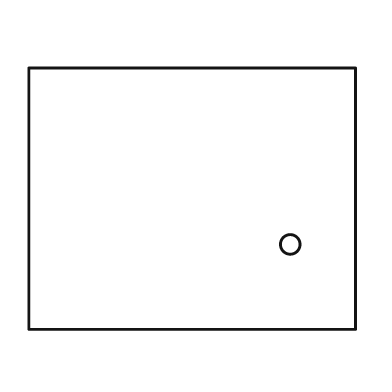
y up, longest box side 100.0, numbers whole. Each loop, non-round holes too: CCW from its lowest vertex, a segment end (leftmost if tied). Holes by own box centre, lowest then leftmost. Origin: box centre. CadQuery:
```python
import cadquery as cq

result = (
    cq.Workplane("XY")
    .moveTo(-50.0, -40.0)
    .lineTo(50.0, -40.0)
    .lineTo(50.0, 40.0)
    .lineTo(-50.0, 40.0)
    .close()
    .moveTo(30.0, -14.0)
    .circle(3.0)
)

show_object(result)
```